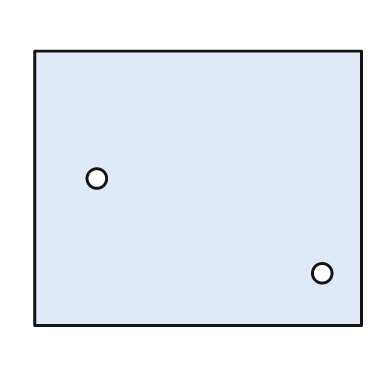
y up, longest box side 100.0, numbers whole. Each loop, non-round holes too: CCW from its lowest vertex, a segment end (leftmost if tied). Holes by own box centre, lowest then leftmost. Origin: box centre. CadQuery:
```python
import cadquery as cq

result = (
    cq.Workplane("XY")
    .moveTo(-50.0, -42.0)
    .lineTo(50.0, -42.0)
    .lineTo(50.0, 42.0)
    .lineTo(-50.0, 42.0)
    .close()
    .moveTo(38.0, -26.0)
    .circle(3.0)
    .moveTo(-31.0, 3.0)
    .circle(3.0)
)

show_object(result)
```